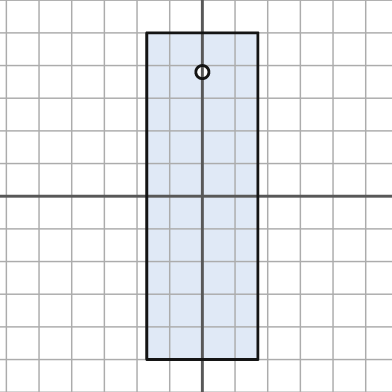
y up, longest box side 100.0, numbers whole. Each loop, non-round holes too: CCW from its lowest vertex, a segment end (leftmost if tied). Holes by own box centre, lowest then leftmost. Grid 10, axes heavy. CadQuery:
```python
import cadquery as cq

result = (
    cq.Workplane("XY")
    .moveTo(-17.0, -50.0)
    .lineTo(17.0, -50.0)
    .lineTo(17.0, 50.0)
    .lineTo(-17.0, 50.0)
    .close()
    .moveTo(0.0, 38.0)
    .circle(2.0)
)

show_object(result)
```